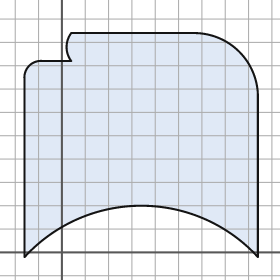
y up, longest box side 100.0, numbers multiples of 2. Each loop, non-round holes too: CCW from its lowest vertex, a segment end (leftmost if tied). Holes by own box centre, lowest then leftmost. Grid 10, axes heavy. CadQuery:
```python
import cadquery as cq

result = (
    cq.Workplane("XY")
    .moveTo(-16.0, -2.0)
    .threePointArc((34.0, 20.0), (84.0, -2.0))
    .lineTo(84.0, 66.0)
    .threePointArc((76.0, 86.0), (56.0, 94.0))
    .lineTo(4.0, 94.0)
    .threePointArc((2.0, 88.0), (4.0, 82.0))
    .lineTo(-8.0, 82.0)
    .threePointArc((-14.0, 80.0), (-16.0, 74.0))
    .close()
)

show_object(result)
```